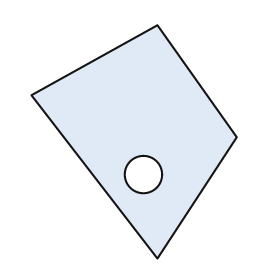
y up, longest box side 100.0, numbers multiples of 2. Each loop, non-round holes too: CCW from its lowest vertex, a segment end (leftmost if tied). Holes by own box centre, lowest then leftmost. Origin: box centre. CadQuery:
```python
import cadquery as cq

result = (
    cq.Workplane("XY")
    .moveTo(10.0, -50.0)
    .lineTo(44.0, 2.0)
    .lineTo(10.0, 50.0)
    .lineTo(-44.0, 20.0)
    .close()
    .moveTo(4.0, -14.0)
    .circle(8.0)
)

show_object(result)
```